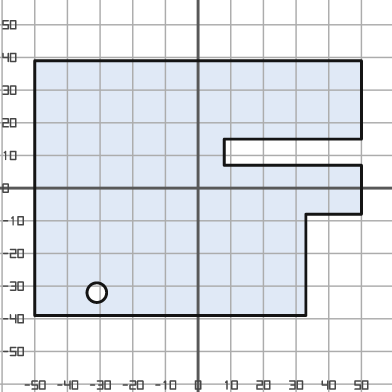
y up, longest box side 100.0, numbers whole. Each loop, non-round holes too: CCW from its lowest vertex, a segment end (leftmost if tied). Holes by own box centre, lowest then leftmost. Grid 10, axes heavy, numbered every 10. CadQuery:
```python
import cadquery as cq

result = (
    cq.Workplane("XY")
    .moveTo(-50.0, -39.0)
    .lineTo(33.0, -39.0)
    .lineTo(33.0, -8.0)
    .lineTo(50.0, -8.0)
    .lineTo(50.0, 7.0)
    .lineTo(8.0, 7.0)
    .lineTo(8.0, 15.0)
    .lineTo(50.0, 15.0)
    .lineTo(50.0, 39.0)
    .lineTo(-50.0, 39.0)
    .close()
    .moveTo(-31.0, -32.0)
    .circle(3.0)
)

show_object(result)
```